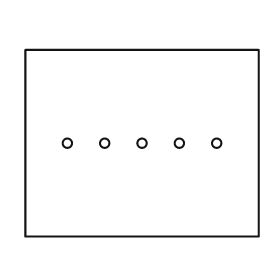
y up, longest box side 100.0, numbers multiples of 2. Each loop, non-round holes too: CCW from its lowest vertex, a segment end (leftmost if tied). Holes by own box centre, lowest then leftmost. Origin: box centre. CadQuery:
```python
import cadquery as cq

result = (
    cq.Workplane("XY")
    .moveTo(-50.0, -40.0)
    .lineTo(50.0, -40.0)
    .lineTo(50.0, 40.0)
    .lineTo(-50.0, 40.0)
    .close()
    .moveTo(-32.0, 0.0)
    .circle(2.0)
    .moveTo(-16.0, 0.0)
    .circle(2.0)
    .moveTo(0.0, 0.0)
    .circle(2.0)
    .moveTo(16.0, 0.0)
    .circle(2.0)
    .moveTo(32.0, 0.0)
    .circle(2.0)
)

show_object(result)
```